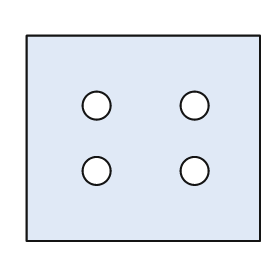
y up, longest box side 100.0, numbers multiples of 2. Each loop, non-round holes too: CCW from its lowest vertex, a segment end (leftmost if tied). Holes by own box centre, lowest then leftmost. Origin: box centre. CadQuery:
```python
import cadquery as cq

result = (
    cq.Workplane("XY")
    .moveTo(-50.0, -44.0)
    .lineTo(50.0, -44.0)
    .lineTo(50.0, 44.0)
    .lineTo(-50.0, 44.0)
    .close()
    .moveTo(-20.0, -14.0)
    .circle(6.0)
    .moveTo(22.0, -14.0)
    .circle(6.0)
    .moveTo(-20.0, 14.0)
    .circle(6.0)
    .moveTo(22.0, 14.0)
    .circle(6.0)
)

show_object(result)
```